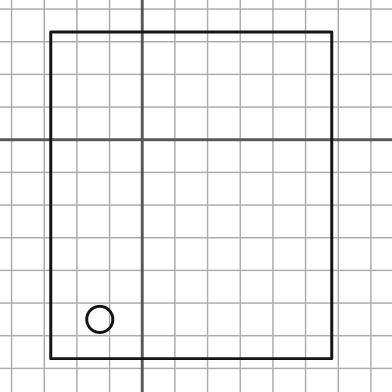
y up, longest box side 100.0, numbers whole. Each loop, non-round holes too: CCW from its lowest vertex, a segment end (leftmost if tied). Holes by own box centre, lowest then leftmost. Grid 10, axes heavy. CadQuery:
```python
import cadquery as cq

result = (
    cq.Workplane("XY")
    .moveTo(-28.0, -67.0)
    .lineTo(58.0, -67.0)
    .lineTo(58.0, 33.0)
    .lineTo(-28.0, 33.0)
    .close()
    .moveTo(-13.0, -55.0)
    .circle(4.0)
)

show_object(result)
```